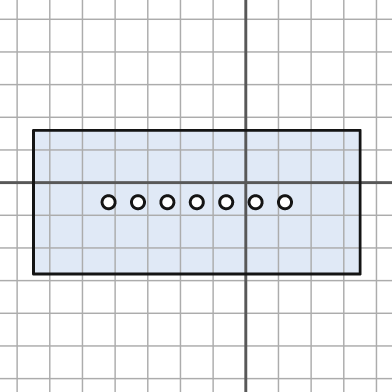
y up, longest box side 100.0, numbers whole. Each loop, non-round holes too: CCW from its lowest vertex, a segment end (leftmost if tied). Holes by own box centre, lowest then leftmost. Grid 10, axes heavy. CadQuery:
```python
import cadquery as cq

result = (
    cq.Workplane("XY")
    .moveTo(-65.0, -28.0)
    .lineTo(35.0, -28.0)
    .lineTo(35.0, 16.0)
    .lineTo(-65.0, 16.0)
    .close()
    .moveTo(-42.0, -6.0)
    .circle(2.0)
    .moveTo(-33.0, -6.0)
    .circle(2.0)
    .moveTo(-24.0, -6.0)
    .circle(2.0)
    .moveTo(-15.0, -6.0)
    .circle(2.0)
    .moveTo(-6.0, -6.0)
    .circle(2.0)
    .moveTo(3.0, -6.0)
    .circle(2.0)
    .moveTo(12.0, -6.0)
    .circle(2.0)
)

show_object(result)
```